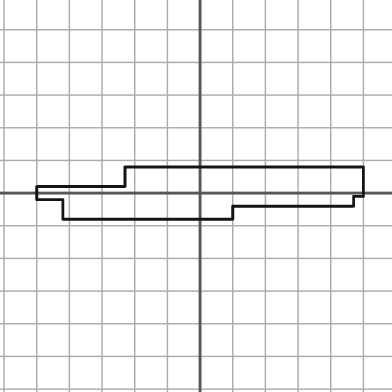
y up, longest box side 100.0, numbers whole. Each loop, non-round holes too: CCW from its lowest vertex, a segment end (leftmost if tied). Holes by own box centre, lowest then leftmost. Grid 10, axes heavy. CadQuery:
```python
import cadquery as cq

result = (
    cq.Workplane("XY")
    .moveTo(-42.0, -8.0)
    .lineTo(10.0, -8.0)
    .lineTo(10.0, -4.0)
    .lineTo(47.0, -4.0)
    .lineTo(47.0, -1.0)
    .lineTo(50.0, -1.0)
    .lineTo(50.0, 8.0)
    .lineTo(-23.0, 8.0)
    .lineTo(-23.0, 2.0)
    .lineTo(-50.0, 2.0)
    .lineTo(-50.0, -2.0)
    .lineTo(-42.0, -2.0)
    .close()
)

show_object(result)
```